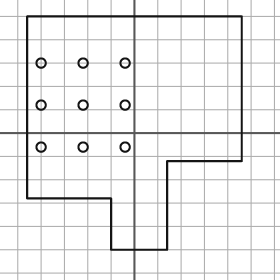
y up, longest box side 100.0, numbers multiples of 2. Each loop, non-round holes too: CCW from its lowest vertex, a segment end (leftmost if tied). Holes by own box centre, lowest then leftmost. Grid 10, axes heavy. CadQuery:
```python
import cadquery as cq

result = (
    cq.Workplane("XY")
    .moveTo(-10.0, -50.0)
    .lineTo(14.0, -50.0)
    .lineTo(14.0, -12.0)
    .lineTo(46.0, -12.0)
    .lineTo(46.0, 50.0)
    .lineTo(-46.0, 50.0)
    .lineTo(-46.0, -28.0)
    .lineTo(-10.0, -28.0)
    .close()
    .moveTo(-40.0, -6.0)
    .circle(2.0)
    .moveTo(-22.0, -6.0)
    .circle(2.0)
    .moveTo(-4.0, -6.0)
    .circle(2.0)
    .moveTo(-40.0, 12.0)
    .circle(2.0)
    .moveTo(-22.0, 12.0)
    .circle(2.0)
    .moveTo(-4.0, 12.0)
    .circle(2.0)
    .moveTo(-40.0, 30.0)
    .circle(2.0)
    .moveTo(-22.0, 30.0)
    .circle(2.0)
    .moveTo(-4.0, 30.0)
    .circle(2.0)
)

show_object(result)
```